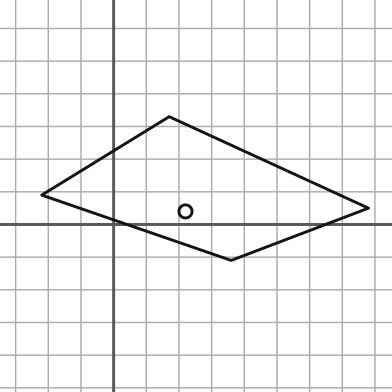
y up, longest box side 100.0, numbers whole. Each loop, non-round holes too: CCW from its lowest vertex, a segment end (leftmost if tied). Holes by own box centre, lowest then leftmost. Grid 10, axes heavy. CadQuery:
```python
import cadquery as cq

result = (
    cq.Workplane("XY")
    .moveTo(36.0, -11.0)
    .lineTo(78.0, 5.0)
    .lineTo(17.0, 33.0)
    .lineTo(-22.0, 9.0)
    .close()
    .moveTo(22.0, 4.0)
    .circle(2.0)
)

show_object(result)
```